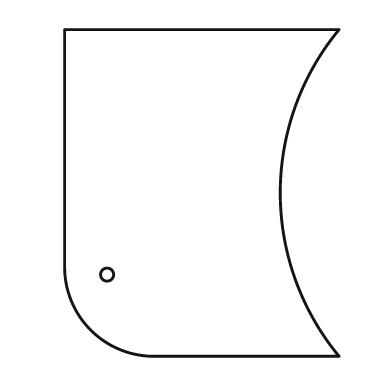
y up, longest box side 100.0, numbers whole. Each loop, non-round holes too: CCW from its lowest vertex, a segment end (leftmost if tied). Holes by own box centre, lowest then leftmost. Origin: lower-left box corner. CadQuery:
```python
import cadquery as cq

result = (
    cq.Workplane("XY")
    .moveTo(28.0, 0.0)
    .lineTo(84.0, 0.0)
    .threePointArc((66.0, 50.0), (84.0, 100.0))
    .lineTo(0.0, 100.0)
    .lineTo(0.0, 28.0)
    .threePointArc((8.0, 8.0), (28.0, 0.0))
    .close()
    .moveTo(13.0, 25.0)
    .circle(2.0)
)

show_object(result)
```